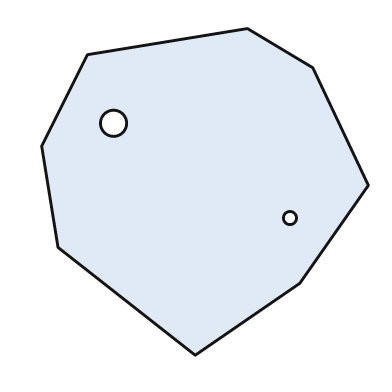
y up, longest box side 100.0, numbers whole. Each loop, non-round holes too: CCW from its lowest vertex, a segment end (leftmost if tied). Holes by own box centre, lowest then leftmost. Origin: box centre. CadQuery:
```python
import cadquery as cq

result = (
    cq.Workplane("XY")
    .moveTo(-3.0, -50.0)
    .lineTo(29.0, -28.0)
    .lineTo(50.0, 2.0)
    .lineTo(33.0, 38.0)
    .lineTo(13.0, 50.0)
    .lineTo(-36.0, 42.0)
    .lineTo(-50.0, 14.0)
    .lineTo(-45.0, -17.0)
    .close()
    .moveTo(26.0, -8.0)
    .circle(2.0)
    .moveTo(-28.0, 21.0)
    .circle(4.0)
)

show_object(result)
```